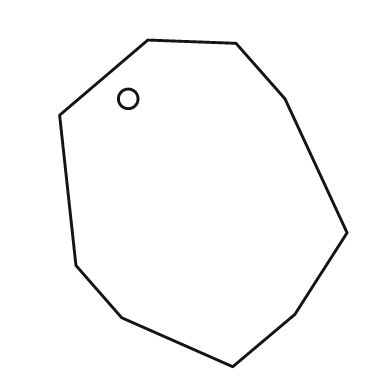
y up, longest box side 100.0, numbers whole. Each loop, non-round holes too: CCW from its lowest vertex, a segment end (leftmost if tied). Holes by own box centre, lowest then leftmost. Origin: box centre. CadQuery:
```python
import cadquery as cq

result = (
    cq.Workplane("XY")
    .moveTo(9.0, -50.0)
    .lineTo(28.0, -34.0)
    .lineTo(44.0, -9.0)
    .lineTo(25.0, 32.0)
    .lineTo(10.0, 49.0)
    .lineTo(-17.0, 50.0)
    .lineTo(-44.0, 27.0)
    .lineTo(-39.0, -19.0)
    .lineTo(-25.0, -35.0)
    .close()
    .moveTo(-23.0, 32.0)
    .circle(3.0)
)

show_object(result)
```